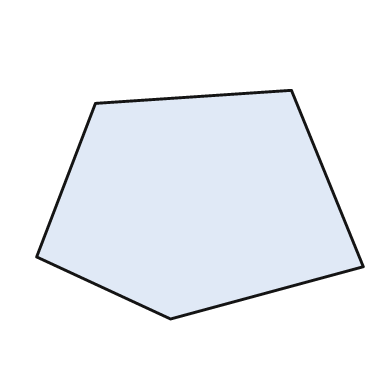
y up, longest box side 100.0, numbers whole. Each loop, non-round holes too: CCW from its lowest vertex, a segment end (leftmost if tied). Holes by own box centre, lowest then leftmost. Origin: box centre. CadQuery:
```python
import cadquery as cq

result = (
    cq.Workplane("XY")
    .moveTo(-9.0, -35.0)
    .lineTo(50.0, -19.0)
    .lineTo(28.0, 35.0)
    .lineTo(-32.0, 31.0)
    .lineTo(-50.0, -16.0)
    .close()
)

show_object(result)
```